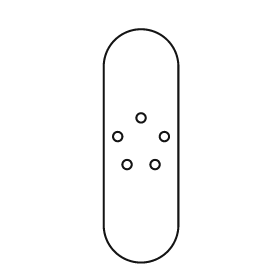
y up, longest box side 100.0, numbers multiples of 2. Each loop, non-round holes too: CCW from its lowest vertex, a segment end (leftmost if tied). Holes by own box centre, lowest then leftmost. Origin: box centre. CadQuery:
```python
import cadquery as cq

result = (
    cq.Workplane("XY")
    .moveTo(-16.0, -34.0)
    .threePointArc((0.0, -50.0), (16.0, -34.0))
    .lineTo(16.0, 34.0)
    .threePointArc((0.0, 50.0), (-16.0, 34.0))
    .close()
    .moveTo(-6.0, -8.0)
    .circle(2.0)
    .moveTo(6.0, -8.0)
    .circle(2.0)
    .moveTo(-10.0, 4.0)
    .circle(2.0)
    .moveTo(10.0, 4.0)
    .circle(2.0)
    .moveTo(0.0, 12.0)
    .circle(2.0)
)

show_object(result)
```